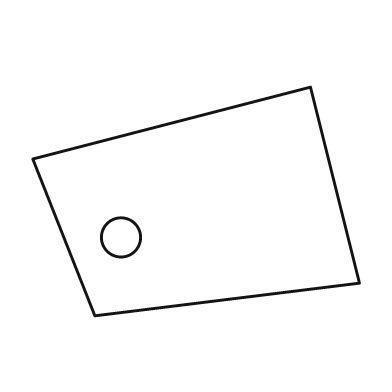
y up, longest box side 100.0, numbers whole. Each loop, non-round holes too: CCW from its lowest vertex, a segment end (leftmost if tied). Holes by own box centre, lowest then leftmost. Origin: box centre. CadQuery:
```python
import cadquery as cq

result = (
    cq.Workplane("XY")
    .moveTo(-31.0, -35.0)
    .lineTo(50.0, -25.0)
    .lineTo(35.0, 35.0)
    .lineTo(-50.0, 13.0)
    .close()
    .moveTo(-23.0, -11.0)
    .circle(6.0)
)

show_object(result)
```